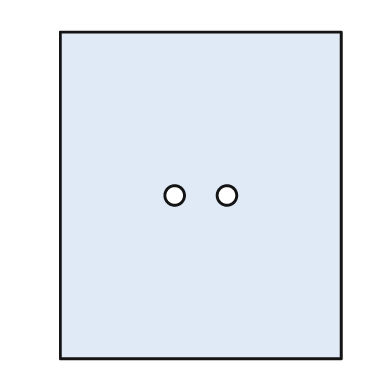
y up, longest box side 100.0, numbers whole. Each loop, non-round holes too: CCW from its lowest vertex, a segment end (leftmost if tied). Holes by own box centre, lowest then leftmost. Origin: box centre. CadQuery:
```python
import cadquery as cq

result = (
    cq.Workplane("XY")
    .moveTo(-43.0, -50.0)
    .lineTo(43.0, -50.0)
    .lineTo(43.0, 50.0)
    .lineTo(-43.0, 50.0)
    .close()
    .moveTo(-8.0, 0.0)
    .circle(3.0)
    .moveTo(8.0, 0.0)
    .circle(3.0)
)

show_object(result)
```